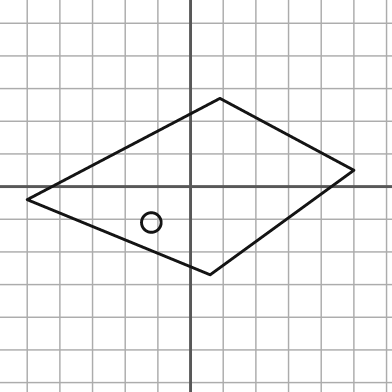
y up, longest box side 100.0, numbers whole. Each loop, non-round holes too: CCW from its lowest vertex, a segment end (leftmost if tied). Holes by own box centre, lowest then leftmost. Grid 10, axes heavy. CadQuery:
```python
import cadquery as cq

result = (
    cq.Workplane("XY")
    .moveTo(6.0, -27.0)
    .lineTo(50.0, 5.0)
    .lineTo(9.0, 27.0)
    .lineTo(-50.0, -4.0)
    .close()
    .moveTo(-12.0, -11.0)
    .circle(3.0)
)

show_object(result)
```